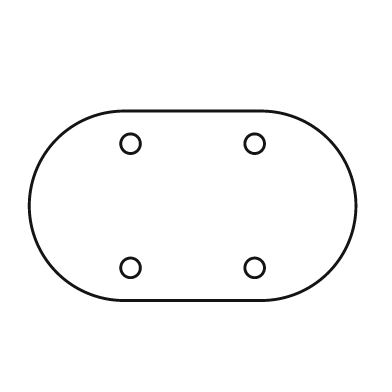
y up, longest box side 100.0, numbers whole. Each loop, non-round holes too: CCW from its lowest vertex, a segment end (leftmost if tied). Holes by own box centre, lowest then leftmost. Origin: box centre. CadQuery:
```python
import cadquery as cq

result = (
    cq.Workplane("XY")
    .moveTo(-21.0, -29.0)
    .lineTo(21.0, -29.0)
    .threePointArc((50.0, 0.0), (21.0, 29.0))
    .lineTo(-21.0, 29.0)
    .threePointArc((-50.0, 0.0), (-21.0, -29.0))
    .close()
    .moveTo(-19.0, -19.0)
    .circle(3.0)
    .moveTo(19.0, -19.0)
    .circle(3.0)
    .moveTo(-19.0, 19.0)
    .circle(3.0)
    .moveTo(19.0, 19.0)
    .circle(3.0)
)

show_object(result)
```